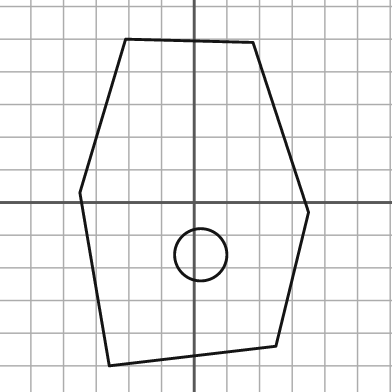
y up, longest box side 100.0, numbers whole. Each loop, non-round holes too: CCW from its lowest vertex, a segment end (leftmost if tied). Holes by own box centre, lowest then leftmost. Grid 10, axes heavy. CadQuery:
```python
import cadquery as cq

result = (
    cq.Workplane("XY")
    .moveTo(-26.0, -50.0)
    .lineTo(25.0, -44.0)
    .lineTo(35.0, -3.0)
    .lineTo(18.0, 49.0)
    .lineTo(-21.0, 50.0)
    .lineTo(-35.0, 3.0)
    .close()
    .moveTo(2.0, -16.0)
    .circle(8.0)
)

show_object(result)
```